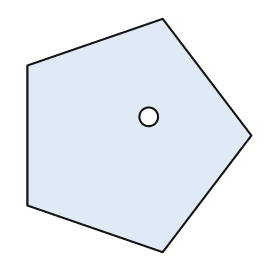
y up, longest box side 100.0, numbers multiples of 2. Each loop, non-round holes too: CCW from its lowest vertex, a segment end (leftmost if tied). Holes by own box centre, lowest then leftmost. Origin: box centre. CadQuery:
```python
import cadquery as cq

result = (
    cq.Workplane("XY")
    .moveTo(10.0, -50.0)
    .lineTo(48.0, 0.0)
    .lineTo(10.0, 50.0)
    .lineTo(-48.0, 30.0)
    .lineTo(-48.0, -30.0)
    .close()
    .moveTo(4.0, 8.0)
    .circle(4.0)
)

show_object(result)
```